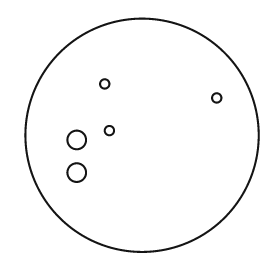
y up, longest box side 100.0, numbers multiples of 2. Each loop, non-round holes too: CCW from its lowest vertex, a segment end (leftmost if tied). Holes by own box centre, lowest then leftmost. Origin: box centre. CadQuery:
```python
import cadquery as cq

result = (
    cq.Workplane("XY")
    .moveTo(0.0, 0.0)
    .circle(50.0)
    .moveTo(-28.0, -16.0)
    .circle(4.0)
    .moveTo(-28.0, -2.0)
    .circle(4.0)
    .moveTo(-14.0, 2.0)
    .circle(2.0)
    .moveTo(32.0, 16.0)
    .circle(2.0)
    .moveTo(-16.0, 22.0)
    .circle(2.0)
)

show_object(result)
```